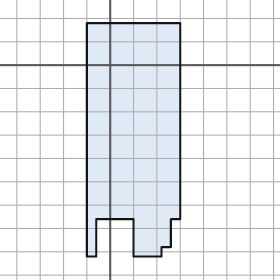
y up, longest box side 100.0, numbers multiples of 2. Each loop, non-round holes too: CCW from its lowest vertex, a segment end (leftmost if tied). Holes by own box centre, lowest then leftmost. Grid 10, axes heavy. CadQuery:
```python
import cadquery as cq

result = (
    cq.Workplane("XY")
    .moveTo(-10.0, -82.0)
    .lineTo(-6.0, -82.0)
    .lineTo(-6.0, -66.0)
    .lineTo(10.0, -66.0)
    .lineTo(10.0, -82.0)
    .lineTo(22.0, -82.0)
    .lineTo(22.0, -78.0)
    .lineTo(26.0, -78.0)
    .lineTo(26.0, -66.0)
    .lineTo(30.0, -66.0)
    .lineTo(30.0, 18.0)
    .lineTo(-10.0, 18.0)
    .close()
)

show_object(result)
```